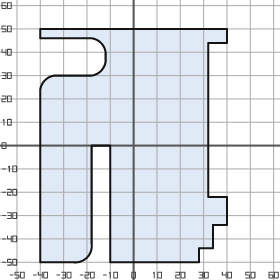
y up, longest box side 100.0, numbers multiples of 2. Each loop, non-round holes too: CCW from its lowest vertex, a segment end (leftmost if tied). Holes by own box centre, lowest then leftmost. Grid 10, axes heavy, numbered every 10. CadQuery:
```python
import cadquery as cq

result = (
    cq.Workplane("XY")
    .moveTo(-40.0, -50.0)
    .lineTo(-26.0, -50.0)
    .threePointArc((-20.0, -48.0), (-18.0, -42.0))
    .lineTo(-18.0, 0.0)
    .lineTo(-10.0, 0.0)
    .lineTo(-10.0, -50.0)
    .lineTo(28.0, -50.0)
    .lineTo(28.0, -44.0)
    .lineTo(34.0, -44.0)
    .lineTo(34.0, -34.0)
    .lineTo(40.0, -34.0)
    .lineTo(40.0, -22.0)
    .lineTo(32.0, -22.0)
    .lineTo(32.0, 44.0)
    .lineTo(40.0, 44.0)
    .lineTo(40.0, 50.0)
    .lineTo(-40.0, 50.0)
    .lineTo(-40.0, 46.0)
    .lineTo(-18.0, 46.0)
    .threePointArc((-14.0, 44.0), (-12.0, 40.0))
    .lineTo(-12.0, 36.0)
    .threePointArc((-14.0, 32.0), (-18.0, 30.0))
    .lineTo(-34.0, 30.0)
    .threePointArc((-38.0, 28.0), (-40.0, 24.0))
    .close()
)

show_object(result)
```